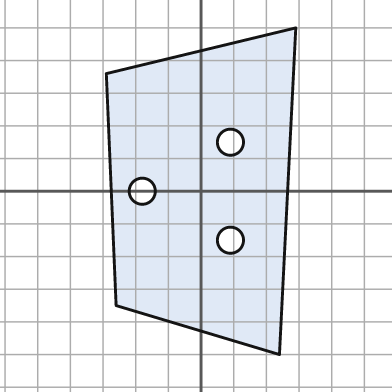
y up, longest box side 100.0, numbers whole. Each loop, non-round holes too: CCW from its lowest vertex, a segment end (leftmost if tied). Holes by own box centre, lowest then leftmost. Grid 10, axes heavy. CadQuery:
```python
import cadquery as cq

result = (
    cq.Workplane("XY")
    .moveTo(24.0, -50.0)
    .lineTo(29.0, 50.0)
    .lineTo(-29.0, 36.0)
    .lineTo(-26.0, -35.0)
    .close()
    .moveTo(9.0, -15.0)
    .circle(4.0)
    .moveTo(-18.0, 0.0)
    .circle(4.0)
    .moveTo(9.0, 15.0)
    .circle(4.0)
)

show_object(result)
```